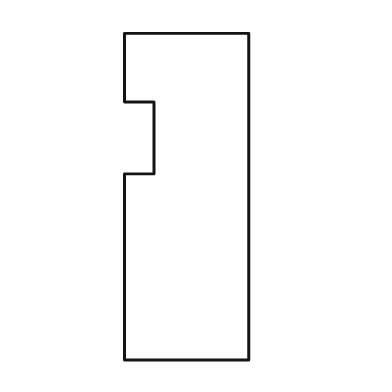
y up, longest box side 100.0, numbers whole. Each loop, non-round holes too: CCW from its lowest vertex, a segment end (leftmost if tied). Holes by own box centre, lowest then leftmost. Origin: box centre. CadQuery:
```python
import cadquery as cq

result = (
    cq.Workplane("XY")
    .moveTo(-19.0, -50.0)
    .lineTo(19.0, -50.0)
    .lineTo(19.0, 50.0)
    .lineTo(-19.0, 50.0)
    .lineTo(-19.0, 29.0)
    .lineTo(-10.0, 29.0)
    .lineTo(-10.0, 7.0)
    .lineTo(-19.0, 7.0)
    .close()
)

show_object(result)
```